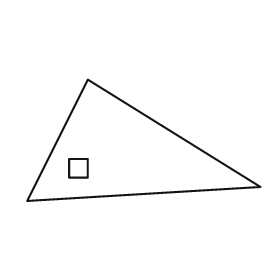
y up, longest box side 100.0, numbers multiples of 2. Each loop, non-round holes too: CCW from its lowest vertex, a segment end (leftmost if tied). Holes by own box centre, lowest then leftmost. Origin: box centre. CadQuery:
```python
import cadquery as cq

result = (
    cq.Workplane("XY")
    .moveTo(-50.0, -26.0)
    .lineTo(50.0, -20.0)
    .lineTo(-24.0, 26.0)
    .close()
    .moveTo(-32.0, -16.0)
    .lineTo(-24.0, -16.0)
    .lineTo(-24.0, -8.0)
    .lineTo(-32.0, -8.0)
    .close()
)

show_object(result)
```